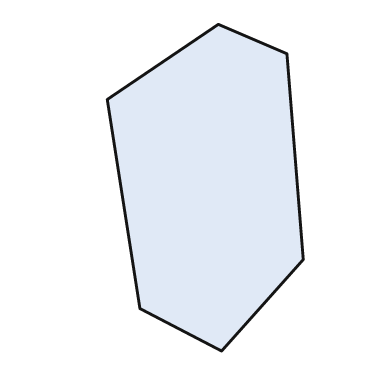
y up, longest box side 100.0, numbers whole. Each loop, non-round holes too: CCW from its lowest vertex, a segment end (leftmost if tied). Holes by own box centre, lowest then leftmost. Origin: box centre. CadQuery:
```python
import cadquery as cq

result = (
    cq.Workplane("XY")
    .moveTo(5.0, -50.0)
    .lineTo(30.0, -22.0)
    .lineTo(25.0, 41.0)
    .lineTo(4.0, 50.0)
    .lineTo(-30.0, 27.0)
    .lineTo(-20.0, -37.0)
    .close()
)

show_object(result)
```